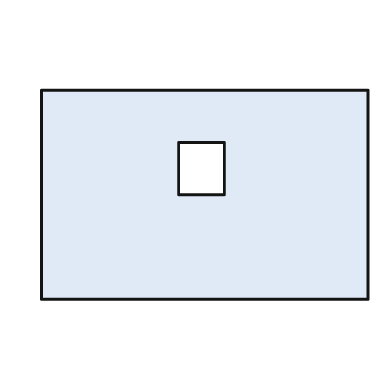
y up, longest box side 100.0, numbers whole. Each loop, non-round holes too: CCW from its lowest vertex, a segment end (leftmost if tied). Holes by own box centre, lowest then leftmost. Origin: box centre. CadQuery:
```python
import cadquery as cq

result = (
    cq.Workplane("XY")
    .moveTo(-50.0, -32.0)
    .lineTo(50.0, -32.0)
    .lineTo(50.0, 32.0)
    .lineTo(-50.0, 32.0)
    .close()
    .moveTo(-8.0, 0.0)
    .lineTo(6.0, 0.0)
    .lineTo(6.0, 16.0)
    .lineTo(-8.0, 16.0)
    .close()
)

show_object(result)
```